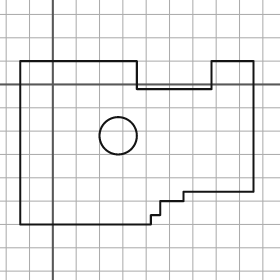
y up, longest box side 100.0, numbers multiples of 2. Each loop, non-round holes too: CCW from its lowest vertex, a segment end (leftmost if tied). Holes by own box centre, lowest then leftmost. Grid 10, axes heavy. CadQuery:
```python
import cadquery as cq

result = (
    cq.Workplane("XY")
    .moveTo(-14.0, -60.0)
    .lineTo(42.0, -60.0)
    .lineTo(42.0, -56.0)
    .lineTo(46.0, -56.0)
    .lineTo(46.0, -50.0)
    .lineTo(56.0, -50.0)
    .lineTo(56.0, -46.0)
    .lineTo(86.0, -46.0)
    .lineTo(86.0, 10.0)
    .lineTo(68.0, 10.0)
    .lineTo(68.0, -2.0)
    .lineTo(36.0, -2.0)
    .lineTo(36.0, 10.0)
    .lineTo(-14.0, 10.0)
    .close()
    .moveTo(28.0, -22.0)
    .circle(8.0)
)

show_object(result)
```